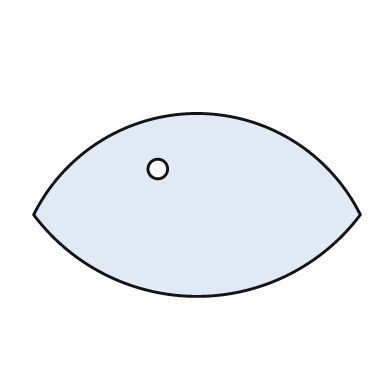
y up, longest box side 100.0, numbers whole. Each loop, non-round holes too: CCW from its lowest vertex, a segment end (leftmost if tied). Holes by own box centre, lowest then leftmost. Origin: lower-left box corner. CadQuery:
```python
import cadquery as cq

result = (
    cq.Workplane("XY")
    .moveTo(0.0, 25.0)
    .threePointArc((50.0, 0.0), (100.0, 25.0))
    .threePointArc((50.0, 56.0), (0.0, 25.0))
    .close()
    .moveTo(38.0, 39.0)
    .circle(3.0)
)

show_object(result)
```